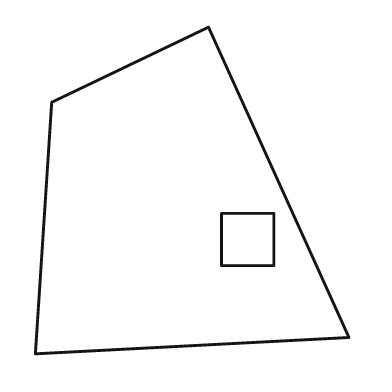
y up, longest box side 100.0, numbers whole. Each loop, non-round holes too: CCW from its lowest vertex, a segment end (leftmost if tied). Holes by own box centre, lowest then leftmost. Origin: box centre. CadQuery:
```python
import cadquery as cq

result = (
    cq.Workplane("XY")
    .moveTo(-48.0, -50.0)
    .lineTo(48.0, -45.0)
    .lineTo(5.0, 50.0)
    .lineTo(-43.0, 27.0)
    .close()
    .moveTo(9.0, -23.0)
    .lineTo(25.0, -23.0)
    .lineTo(25.0, -7.0)
    .lineTo(9.0, -7.0)
    .close()
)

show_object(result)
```